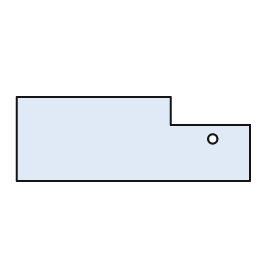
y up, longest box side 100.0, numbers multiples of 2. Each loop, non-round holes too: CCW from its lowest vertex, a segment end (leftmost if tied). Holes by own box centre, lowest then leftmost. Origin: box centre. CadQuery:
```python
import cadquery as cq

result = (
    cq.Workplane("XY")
    .moveTo(-50.0, -18.0)
    .lineTo(50.0, -18.0)
    .lineTo(50.0, 6.0)
    .lineTo(16.0, 6.0)
    .lineTo(16.0, 18.0)
    .lineTo(-50.0, 18.0)
    .close()
    .moveTo(34.0, 0.0)
    .circle(2.0)
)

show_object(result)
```